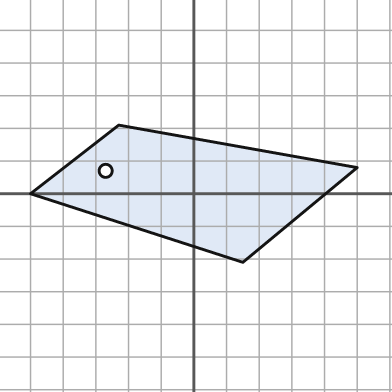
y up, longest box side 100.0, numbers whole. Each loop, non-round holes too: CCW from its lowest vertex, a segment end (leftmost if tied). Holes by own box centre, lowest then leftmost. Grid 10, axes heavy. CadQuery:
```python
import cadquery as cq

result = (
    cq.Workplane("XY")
    .moveTo(15.0, -21.0)
    .lineTo(50.0, 8.0)
    .lineTo(-23.0, 21.0)
    .lineTo(-50.0, 0.0)
    .close()
    .moveTo(-27.0, 7.0)
    .circle(2.0)
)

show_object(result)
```